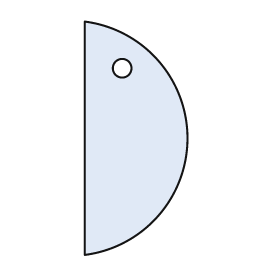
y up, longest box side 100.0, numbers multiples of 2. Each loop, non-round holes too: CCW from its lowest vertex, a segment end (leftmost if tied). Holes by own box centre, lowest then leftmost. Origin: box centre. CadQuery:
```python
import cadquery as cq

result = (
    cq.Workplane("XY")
    .moveTo(-22.0, -50.0)
    .threePointArc((22.0, 0.0), (-22.0, 50.0))
    .close()
    .moveTo(-6.0, 30.0)
    .circle(4.0)
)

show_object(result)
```